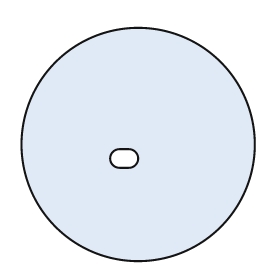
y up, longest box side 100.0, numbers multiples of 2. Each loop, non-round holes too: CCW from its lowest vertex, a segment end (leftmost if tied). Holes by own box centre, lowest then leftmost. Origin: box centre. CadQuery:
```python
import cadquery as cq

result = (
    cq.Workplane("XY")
    .moveTo(0.0, 0.0)
    .circle(50.0)
    .moveTo(-8.0, -10.0)
    .lineTo(-4.0, -10.0)
    .threePointArc((0.0, -6.0), (-4.0, -2.0))
    .lineTo(-8.0, -2.0)
    .threePointArc((-12.0, -6.0), (-8.0, -10.0))
    .close()
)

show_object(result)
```